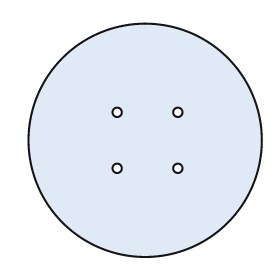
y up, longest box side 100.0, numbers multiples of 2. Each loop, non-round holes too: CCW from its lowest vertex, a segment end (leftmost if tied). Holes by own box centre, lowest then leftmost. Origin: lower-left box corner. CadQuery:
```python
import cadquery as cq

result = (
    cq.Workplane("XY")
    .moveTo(50.0, 50.0)
    .circle(50.0)
    .moveTo(38.0, 38.0)
    .circle(2.0)
    .moveTo(64.0, 38.0)
    .circle(2.0)
    .moveTo(38.0, 62.0)
    .circle(2.0)
    .moveTo(64.0, 62.0)
    .circle(2.0)
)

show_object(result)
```